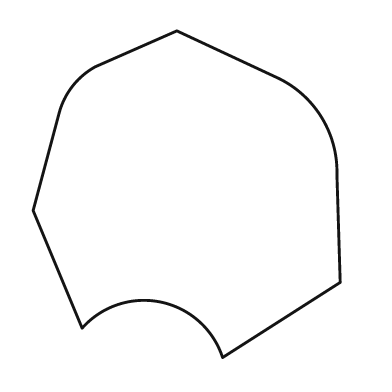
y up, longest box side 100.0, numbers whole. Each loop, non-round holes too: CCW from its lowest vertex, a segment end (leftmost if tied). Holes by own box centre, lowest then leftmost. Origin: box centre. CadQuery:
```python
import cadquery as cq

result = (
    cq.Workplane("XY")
    .moveTo(11.0, -50.0)
    .lineTo(47.0, -27.0)
    .lineTo(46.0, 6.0)
    .threePointArc((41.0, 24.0), (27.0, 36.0))
    .lineTo(-3.0, 50.0)
    .lineTo(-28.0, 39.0)
    .threePointArc((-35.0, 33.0), (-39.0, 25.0))
    .lineTo(-47.0, -5.0)
    .lineTo(-32.0, -41.0)
    .threePointArc((-8.0, -33.0), (11.0, -50.0))
    .close()
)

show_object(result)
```